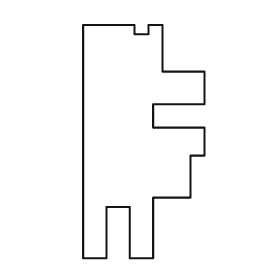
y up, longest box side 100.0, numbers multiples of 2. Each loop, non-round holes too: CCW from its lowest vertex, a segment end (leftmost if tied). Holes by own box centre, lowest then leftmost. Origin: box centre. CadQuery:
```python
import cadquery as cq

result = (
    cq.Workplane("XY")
    .moveTo(-26.0, -50.0)
    .lineTo(-16.0, -50.0)
    .lineTo(-16.0, -28.0)
    .lineTo(-6.0, -28.0)
    .lineTo(-6.0, -50.0)
    .lineTo(4.0, -50.0)
    .lineTo(4.0, -24.0)
    .lineTo(20.0, -24.0)
    .lineTo(20.0, -6.0)
    .lineTo(26.0, -6.0)
    .lineTo(26.0, 6.0)
    .lineTo(4.0, 6.0)
    .lineTo(4.0, 16.0)
    .lineTo(26.0, 16.0)
    .lineTo(26.0, 30.0)
    .lineTo(8.0, 30.0)
    .lineTo(8.0, 50.0)
    .lineTo(2.0, 50.0)
    .lineTo(2.0, 46.0)
    .lineTo(-4.0, 46.0)
    .lineTo(-4.0, 50.0)
    .lineTo(-26.0, 50.0)
    .close()
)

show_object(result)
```